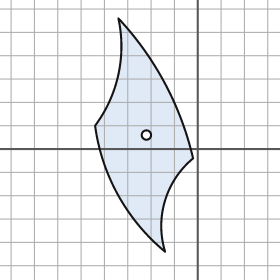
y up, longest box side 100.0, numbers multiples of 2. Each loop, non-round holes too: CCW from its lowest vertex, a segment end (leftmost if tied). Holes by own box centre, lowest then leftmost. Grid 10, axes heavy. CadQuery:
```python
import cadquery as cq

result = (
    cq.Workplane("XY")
    .moveTo(-14.0, -44.0)
    .threePointArc((-14.0, -22.0), (-2.0, -4.0))
    .threePointArc((-14.0, 28.0), (-34.0, 56.0))
    .threePointArc((-34.0, 32.0), (-44.0, 10.0))
    .threePointArc((-34.0, -20.0), (-14.0, -44.0))
    .close()
    .moveTo(-22.0, 6.0)
    .circle(2.0)
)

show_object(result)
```